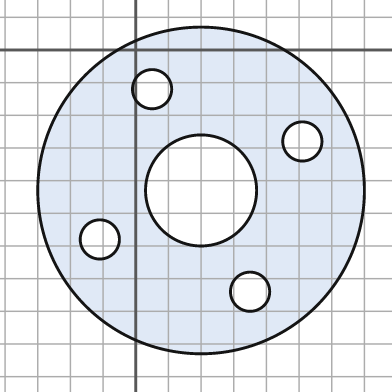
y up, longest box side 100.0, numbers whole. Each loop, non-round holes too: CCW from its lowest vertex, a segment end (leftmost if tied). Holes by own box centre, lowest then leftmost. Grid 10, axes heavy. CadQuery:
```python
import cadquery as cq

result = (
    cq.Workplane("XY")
    .moveTo(20.0, -43.0)
    .circle(50.0)
    .moveTo(35.0, -74.0)
    .circle(6.0)
    .moveTo(-11.0, -58.0)
    .circle(6.0)
    .moveTo(20.0, -43.0)
    .circle(17.0)
    .moveTo(51.0, -28.0)
    .circle(6.0)
    .moveTo(5.0, -12.0)
    .circle(6.0)
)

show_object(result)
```